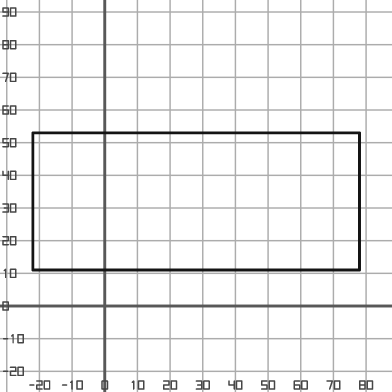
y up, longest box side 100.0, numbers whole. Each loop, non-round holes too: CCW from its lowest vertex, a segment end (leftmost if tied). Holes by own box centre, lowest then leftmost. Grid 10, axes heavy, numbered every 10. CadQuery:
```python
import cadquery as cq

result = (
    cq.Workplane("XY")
    .moveTo(-22.0, 11.0)
    .lineTo(78.0, 11.0)
    .lineTo(78.0, 53.0)
    .lineTo(-22.0, 53.0)
    .close()
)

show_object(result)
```